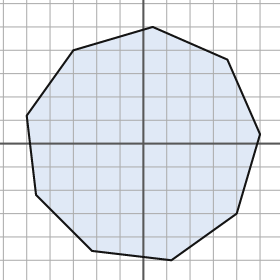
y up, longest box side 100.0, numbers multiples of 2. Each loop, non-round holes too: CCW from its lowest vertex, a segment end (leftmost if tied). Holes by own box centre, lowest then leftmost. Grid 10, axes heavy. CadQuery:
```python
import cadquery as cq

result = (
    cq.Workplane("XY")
    .moveTo(12.0, -50.0)
    .lineTo(40.0, -30.0)
    .lineTo(50.0, 4.0)
    .lineTo(36.0, 36.0)
    .lineTo(4.0, 50.0)
    .lineTo(-30.0, 40.0)
    .lineTo(-50.0, 12.0)
    .lineTo(-46.0, -22.0)
    .lineTo(-22.0, -46.0)
    .close()
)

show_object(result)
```